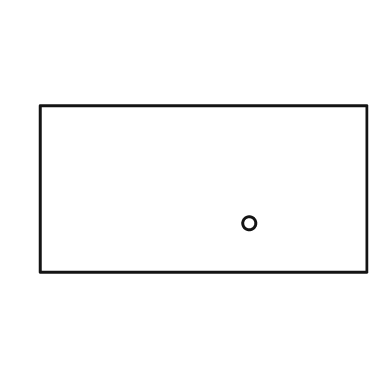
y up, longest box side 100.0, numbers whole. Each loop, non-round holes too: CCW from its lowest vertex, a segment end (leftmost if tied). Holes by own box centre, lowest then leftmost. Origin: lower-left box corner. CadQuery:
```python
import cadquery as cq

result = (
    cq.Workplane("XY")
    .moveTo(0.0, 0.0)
    .lineTo(100.0, 0.0)
    .lineTo(100.0, 51.0)
    .lineTo(0.0, 51.0)
    .close()
    .moveTo(64.0, 15.0)
    .circle(2.0)
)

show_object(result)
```